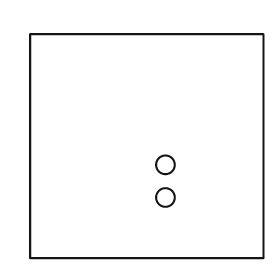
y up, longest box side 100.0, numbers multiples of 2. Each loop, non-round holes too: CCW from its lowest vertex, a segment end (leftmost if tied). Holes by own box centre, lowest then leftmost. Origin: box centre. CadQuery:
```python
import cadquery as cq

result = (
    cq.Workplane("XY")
    .moveTo(-50.0, -48.0)
    .lineTo(50.0, -48.0)
    .lineTo(50.0, 48.0)
    .lineTo(-50.0, 48.0)
    .close()
    .moveTo(8.0, -22.0)
    .circle(4.0)
    .moveTo(8.0, -8.0)
    .circle(4.0)
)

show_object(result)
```